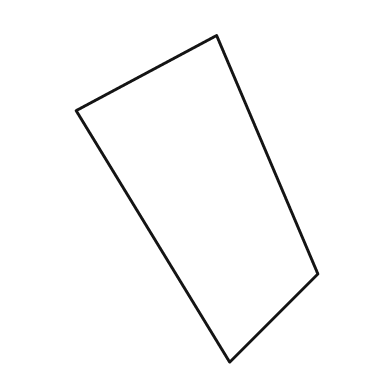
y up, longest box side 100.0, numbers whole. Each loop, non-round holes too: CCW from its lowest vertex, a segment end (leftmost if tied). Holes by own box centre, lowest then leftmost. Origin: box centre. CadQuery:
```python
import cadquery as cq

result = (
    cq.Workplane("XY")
    .moveTo(10.0, -50.0)
    .lineTo(37.0, -23.0)
    .lineTo(6.0, 50.0)
    .lineTo(-37.0, 27.0)
    .close()
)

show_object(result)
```